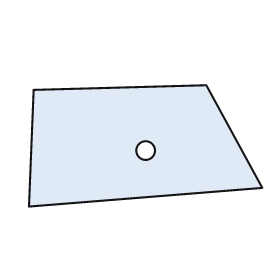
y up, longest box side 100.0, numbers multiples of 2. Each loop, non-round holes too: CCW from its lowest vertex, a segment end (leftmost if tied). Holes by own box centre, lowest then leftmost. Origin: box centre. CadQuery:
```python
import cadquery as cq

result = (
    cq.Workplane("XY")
    .moveTo(-50.0, -26.0)
    .lineTo(50.0, -18.0)
    .lineTo(26.0, 26.0)
    .lineTo(-48.0, 24.0)
    .close()
    .moveTo(0.0, -2.0)
    .circle(4.0)
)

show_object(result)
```